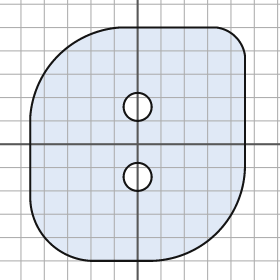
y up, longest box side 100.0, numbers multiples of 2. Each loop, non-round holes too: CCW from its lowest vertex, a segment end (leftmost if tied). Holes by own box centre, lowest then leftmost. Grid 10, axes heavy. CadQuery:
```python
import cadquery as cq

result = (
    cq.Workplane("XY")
    .moveTo(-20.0, -50.0)
    .lineTo(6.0, -50.0)
    .threePointArc((34.0, -38.0), (46.0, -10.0))
    .lineTo(46.0, 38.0)
    .threePointArc((42.0, 46.0), (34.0, 50.0))
    .lineTo(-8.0, 50.0)
    .threePointArc((-34.0, 38.0), (-46.0, 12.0))
    .lineTo(-46.0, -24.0)
    .threePointArc((-38.0, -42.0), (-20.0, -50.0))
    .close()
    .moveTo(0.0, -14.0)
    .circle(6.0)
    .moveTo(0.0, 16.0)
    .circle(6.0)
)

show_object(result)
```